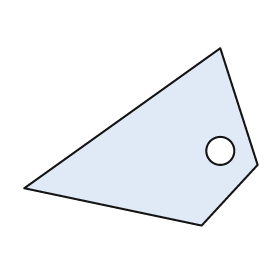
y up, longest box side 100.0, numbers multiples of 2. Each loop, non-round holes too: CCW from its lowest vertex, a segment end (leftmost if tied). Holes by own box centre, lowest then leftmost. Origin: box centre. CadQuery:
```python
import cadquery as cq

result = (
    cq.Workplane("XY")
    .moveTo(26.0, -38.0)
    .lineTo(50.0, -12.0)
    .lineTo(34.0, 38.0)
    .lineTo(-50.0, -22.0)
    .close()
    .moveTo(34.0, -6.0)
    .circle(6.0)
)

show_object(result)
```